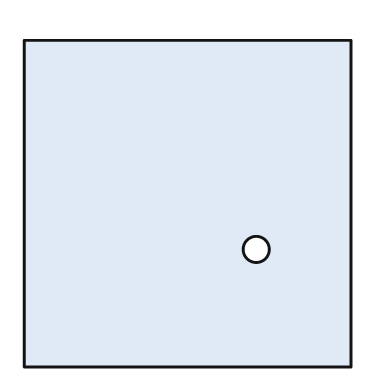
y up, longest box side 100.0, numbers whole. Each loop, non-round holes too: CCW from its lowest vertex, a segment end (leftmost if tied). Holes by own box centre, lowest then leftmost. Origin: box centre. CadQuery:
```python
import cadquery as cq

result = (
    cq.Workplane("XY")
    .moveTo(-50.0, -50.0)
    .lineTo(50.0, -50.0)
    .lineTo(50.0, 50.0)
    .lineTo(-50.0, 50.0)
    .close()
    .moveTo(21.0, -14.0)
    .circle(4.0)
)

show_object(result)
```